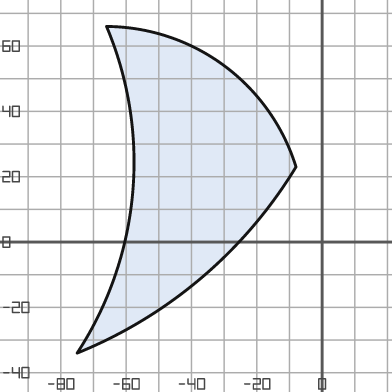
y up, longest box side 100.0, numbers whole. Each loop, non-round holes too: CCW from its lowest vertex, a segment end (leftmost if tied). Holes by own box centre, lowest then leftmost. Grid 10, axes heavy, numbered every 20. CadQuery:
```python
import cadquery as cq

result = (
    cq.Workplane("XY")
    .moveTo(-75.0, -34.0)
    .threePointArc((-37.0, -11.0), (-8.0, 23.0))
    .threePointArc((-30.0, 54.0), (-66.0, 66.0))
    .threePointArc((-58.0, 15.0), (-75.0, -34.0))
    .close()
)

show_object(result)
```